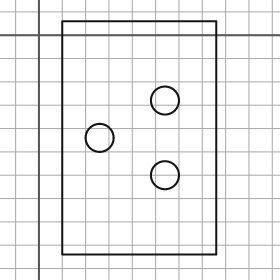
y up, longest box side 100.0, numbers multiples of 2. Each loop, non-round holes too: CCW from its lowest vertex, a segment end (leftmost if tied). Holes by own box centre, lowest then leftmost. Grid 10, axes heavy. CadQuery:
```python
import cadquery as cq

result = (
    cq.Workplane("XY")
    .moveTo(10.0, -94.0)
    .lineTo(76.0, -94.0)
    .lineTo(76.0, 6.0)
    .lineTo(10.0, 6.0)
    .close()
    .moveTo(54.0, -60.0)
    .circle(6.0)
    .moveTo(26.0, -44.0)
    .circle(6.0)
    .moveTo(54.0, -28.0)
    .circle(6.0)
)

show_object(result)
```